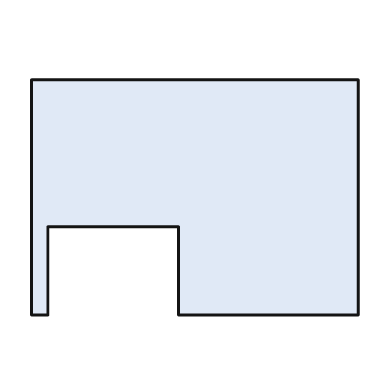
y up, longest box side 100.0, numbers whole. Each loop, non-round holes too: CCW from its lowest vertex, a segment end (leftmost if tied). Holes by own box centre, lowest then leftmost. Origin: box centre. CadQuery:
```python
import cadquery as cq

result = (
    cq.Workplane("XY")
    .moveTo(-50.0, -36.0)
    .lineTo(-45.0, -36.0)
    .lineTo(-45.0, -9.0)
    .lineTo(-5.0, -9.0)
    .lineTo(-5.0, -36.0)
    .lineTo(50.0, -36.0)
    .lineTo(50.0, 36.0)
    .lineTo(-50.0, 36.0)
    .close()
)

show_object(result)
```